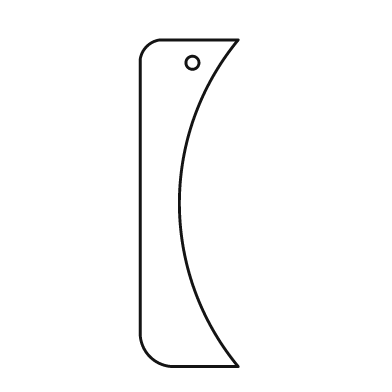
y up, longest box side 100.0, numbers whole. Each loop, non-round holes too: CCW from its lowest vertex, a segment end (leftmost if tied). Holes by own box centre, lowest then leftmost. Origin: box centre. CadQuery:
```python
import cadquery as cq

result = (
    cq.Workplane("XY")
    .moveTo(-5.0, -50.0)
    .lineTo(15.0, -50.0)
    .threePointArc((-3.0, 0.0), (15.0, 50.0))
    .lineTo(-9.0, 50.0)
    .threePointArc((-13.0, 48.0), (-15.0, 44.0))
    .lineTo(-15.0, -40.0)
    .threePointArc((-12.0, -47.0), (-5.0, -50.0))
    .close()
    .moveTo(1.0, 43.0)
    .circle(2.0)
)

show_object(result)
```